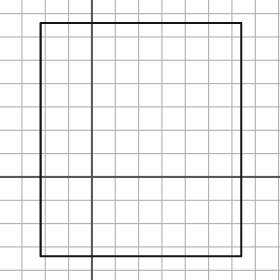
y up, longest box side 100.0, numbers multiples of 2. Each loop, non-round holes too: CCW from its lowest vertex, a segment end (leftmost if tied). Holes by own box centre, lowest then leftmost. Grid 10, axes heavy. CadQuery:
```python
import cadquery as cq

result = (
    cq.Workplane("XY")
    .moveTo(-22.0, -34.0)
    .lineTo(64.0, -34.0)
    .lineTo(64.0, 66.0)
    .lineTo(-22.0, 66.0)
    .close()
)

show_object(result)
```